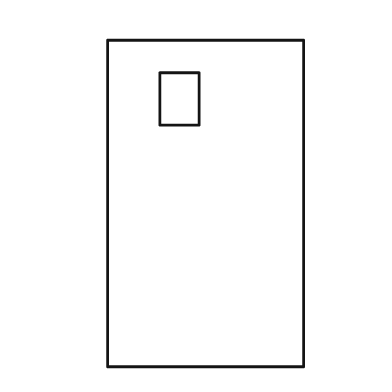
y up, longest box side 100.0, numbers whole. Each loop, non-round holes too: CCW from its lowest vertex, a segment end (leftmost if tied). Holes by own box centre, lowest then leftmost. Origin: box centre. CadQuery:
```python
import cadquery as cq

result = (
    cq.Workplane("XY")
    .moveTo(-30.0, -50.0)
    .lineTo(30.0, -50.0)
    .lineTo(30.0, 50.0)
    .lineTo(-30.0, 50.0)
    .close()
    .moveTo(-14.0, 24.0)
    .lineTo(-2.0, 24.0)
    .lineTo(-2.0, 40.0)
    .lineTo(-14.0, 40.0)
    .close()
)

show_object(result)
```